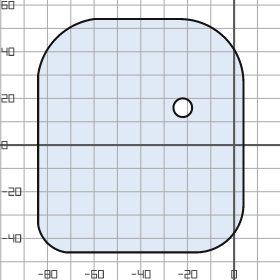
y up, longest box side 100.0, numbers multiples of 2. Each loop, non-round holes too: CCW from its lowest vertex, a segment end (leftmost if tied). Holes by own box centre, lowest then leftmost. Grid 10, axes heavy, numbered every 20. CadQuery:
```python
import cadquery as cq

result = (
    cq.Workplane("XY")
    .moveTo(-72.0, -46.0)
    .lineTo(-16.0, -46.0)
    .threePointArc((-2.0, -40.0), (4.0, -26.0))
    .lineTo(4.0, 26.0)
    .threePointArc((-4.0, 46.0), (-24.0, 54.0))
    .lineTo(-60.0, 54.0)
    .threePointArc((-76.0, 46.0), (-84.0, 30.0))
    .lineTo(-84.0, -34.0)
    .threePointArc((-80.0, -42.0), (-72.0, -46.0))
    .close()
    .moveTo(-22.0, 16.0)
    .circle(4.0)
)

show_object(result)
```